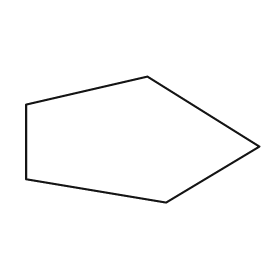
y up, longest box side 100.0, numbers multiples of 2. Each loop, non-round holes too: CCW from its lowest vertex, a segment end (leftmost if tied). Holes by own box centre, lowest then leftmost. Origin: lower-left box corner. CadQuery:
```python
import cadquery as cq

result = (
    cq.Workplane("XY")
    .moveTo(60.0, 0.0)
    .lineTo(100.0, 24.0)
    .lineTo(52.0, 54.0)
    .lineTo(0.0, 42.0)
    .lineTo(0.0, 10.0)
    .close()
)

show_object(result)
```